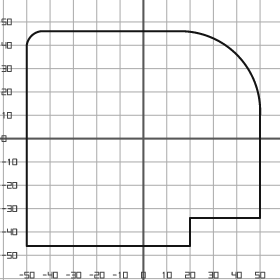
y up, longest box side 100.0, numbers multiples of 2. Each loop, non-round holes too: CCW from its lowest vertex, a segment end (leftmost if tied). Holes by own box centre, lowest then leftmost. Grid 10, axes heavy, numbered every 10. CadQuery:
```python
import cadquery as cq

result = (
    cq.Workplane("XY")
    .moveTo(-50.0, -46.0)
    .lineTo(20.0, -46.0)
    .lineTo(20.0, -34.0)
    .lineTo(50.0, -34.0)
    .lineTo(50.0, 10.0)
    .threePointArc((40.0, 36.0), (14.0, 46.0))
    .lineTo(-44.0, 46.0)
    .threePointArc((-48.0, 44.0), (-50.0, 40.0))
    .close()
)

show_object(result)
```